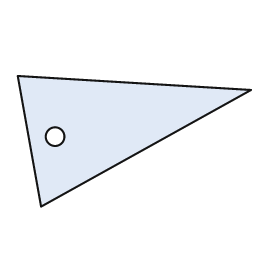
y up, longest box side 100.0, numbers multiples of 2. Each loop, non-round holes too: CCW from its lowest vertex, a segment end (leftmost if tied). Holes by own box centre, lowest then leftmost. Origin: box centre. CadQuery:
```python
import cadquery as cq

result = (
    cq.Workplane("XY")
    .moveTo(-40.0, -28.0)
    .lineTo(50.0, 22.0)
    .lineTo(-50.0, 28.0)
    .close()
    .moveTo(-34.0, 2.0)
    .circle(4.0)
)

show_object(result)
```